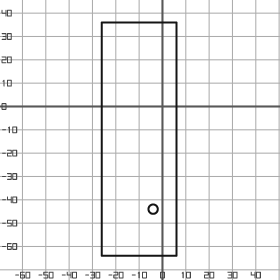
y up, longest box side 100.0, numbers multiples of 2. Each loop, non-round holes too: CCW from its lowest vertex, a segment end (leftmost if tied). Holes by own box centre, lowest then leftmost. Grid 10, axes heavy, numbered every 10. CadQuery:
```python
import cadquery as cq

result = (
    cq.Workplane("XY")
    .moveTo(-26.0, -64.0)
    .lineTo(6.0, -64.0)
    .lineTo(6.0, 36.0)
    .lineTo(-26.0, 36.0)
    .close()
    .moveTo(-4.0, -44.0)
    .circle(2.0)
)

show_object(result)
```